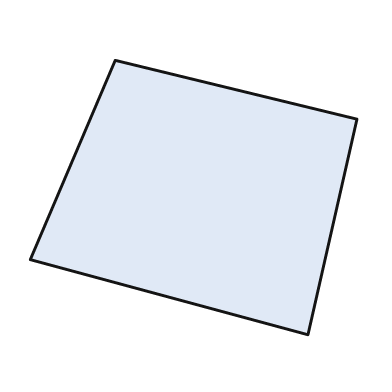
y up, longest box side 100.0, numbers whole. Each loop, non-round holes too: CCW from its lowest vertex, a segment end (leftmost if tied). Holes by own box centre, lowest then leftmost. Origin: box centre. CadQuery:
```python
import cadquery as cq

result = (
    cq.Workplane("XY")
    .moveTo(35.0, -42.0)
    .lineTo(50.0, 24.0)
    .lineTo(-24.0, 42.0)
    .lineTo(-50.0, -19.0)
    .close()
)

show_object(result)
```